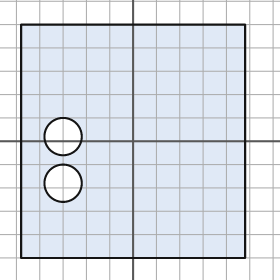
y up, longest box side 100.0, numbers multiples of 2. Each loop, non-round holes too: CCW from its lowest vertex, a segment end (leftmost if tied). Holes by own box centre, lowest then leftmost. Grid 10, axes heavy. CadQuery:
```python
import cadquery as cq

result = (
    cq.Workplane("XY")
    .moveTo(-48.0, -50.0)
    .lineTo(48.0, -50.0)
    .lineTo(48.0, 50.0)
    .lineTo(-48.0, 50.0)
    .close()
    .moveTo(-30.0, -18.0)
    .circle(8.0)
    .moveTo(-30.0, 2.0)
    .circle(8.0)
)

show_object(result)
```